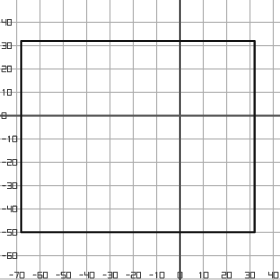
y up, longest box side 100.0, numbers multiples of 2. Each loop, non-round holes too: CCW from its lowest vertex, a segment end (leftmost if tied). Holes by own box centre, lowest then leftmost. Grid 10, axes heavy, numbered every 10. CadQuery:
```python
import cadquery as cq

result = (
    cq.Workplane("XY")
    .moveTo(-68.0, -50.0)
    .lineTo(32.0, -50.0)
    .lineTo(32.0, 32.0)
    .lineTo(-68.0, 32.0)
    .close()
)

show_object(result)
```